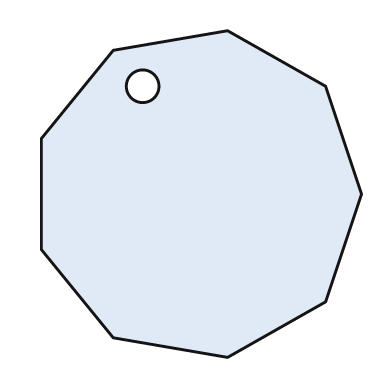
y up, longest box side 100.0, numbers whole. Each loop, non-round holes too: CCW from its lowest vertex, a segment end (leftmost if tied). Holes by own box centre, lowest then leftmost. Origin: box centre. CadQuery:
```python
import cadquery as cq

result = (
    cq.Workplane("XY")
    .moveTo(8.0, -50.0)
    .lineTo(38.0, -33.0)
    .lineTo(49.0, 0.0)
    .lineTo(38.0, 33.0)
    .lineTo(8.0, 50.0)
    .lineTo(-27.0, 44.0)
    .lineTo(-49.0, 17.0)
    .lineTo(-49.0, -17.0)
    .lineTo(-27.0, -44.0)
    .close()
    .moveTo(-18.0, 33.0)
    .circle(5.0)
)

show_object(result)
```